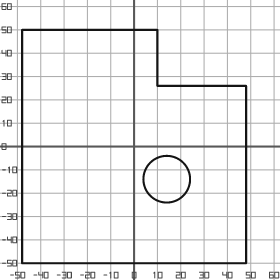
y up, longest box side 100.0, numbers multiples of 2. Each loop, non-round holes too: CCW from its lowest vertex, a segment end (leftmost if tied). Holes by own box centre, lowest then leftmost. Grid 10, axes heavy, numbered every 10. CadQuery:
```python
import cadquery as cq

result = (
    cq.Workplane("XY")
    .moveTo(-48.0, -50.0)
    .lineTo(48.0, -50.0)
    .lineTo(48.0, 26.0)
    .lineTo(10.0, 26.0)
    .lineTo(10.0, 50.0)
    .lineTo(-48.0, 50.0)
    .close()
    .moveTo(14.0, -14.0)
    .circle(10.0)
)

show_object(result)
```